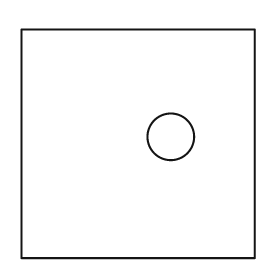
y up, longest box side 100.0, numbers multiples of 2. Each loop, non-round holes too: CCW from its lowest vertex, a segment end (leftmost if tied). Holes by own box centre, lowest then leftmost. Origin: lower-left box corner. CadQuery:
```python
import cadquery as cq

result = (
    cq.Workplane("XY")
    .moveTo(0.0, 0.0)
    .lineTo(100.0, 0.0)
    .lineTo(100.0, 98.0)
    .lineTo(0.0, 98.0)
    .close()
    .moveTo(64.0, 52.0)
    .circle(10.0)
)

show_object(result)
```